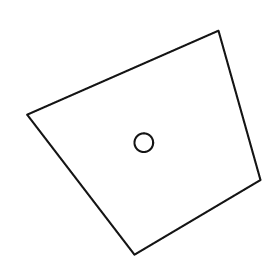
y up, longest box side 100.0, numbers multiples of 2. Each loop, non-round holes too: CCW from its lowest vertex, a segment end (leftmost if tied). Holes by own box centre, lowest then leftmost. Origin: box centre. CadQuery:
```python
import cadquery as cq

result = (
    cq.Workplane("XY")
    .moveTo(-4.0, -48.0)
    .lineTo(50.0, -16.0)
    .lineTo(32.0, 48.0)
    .lineTo(-50.0, 12.0)
    .close()
    .moveTo(0.0, 0.0)
    .circle(4.0)
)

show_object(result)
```